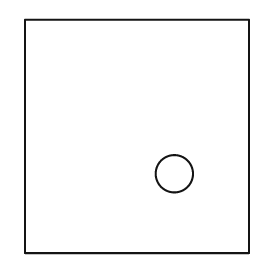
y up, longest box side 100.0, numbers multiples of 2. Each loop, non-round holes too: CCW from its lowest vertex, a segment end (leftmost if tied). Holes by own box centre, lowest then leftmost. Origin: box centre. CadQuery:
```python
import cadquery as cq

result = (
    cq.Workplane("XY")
    .moveTo(-48.0, -50.0)
    .lineTo(48.0, -50.0)
    .lineTo(48.0, 50.0)
    .lineTo(-48.0, 50.0)
    .close()
    .moveTo(16.0, -16.0)
    .circle(8.0)
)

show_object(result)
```